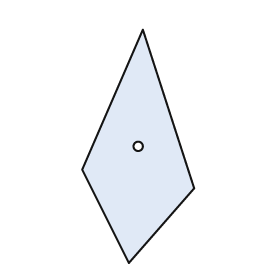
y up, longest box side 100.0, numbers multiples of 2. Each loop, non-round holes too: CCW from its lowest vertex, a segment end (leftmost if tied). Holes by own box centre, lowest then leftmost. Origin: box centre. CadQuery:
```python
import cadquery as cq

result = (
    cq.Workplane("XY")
    .moveTo(-4.0, -50.0)
    .lineTo(24.0, -18.0)
    .lineTo(2.0, 50.0)
    .lineTo(-24.0, -10.0)
    .close()
    .moveTo(0.0, 0.0)
    .circle(2.0)
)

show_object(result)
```